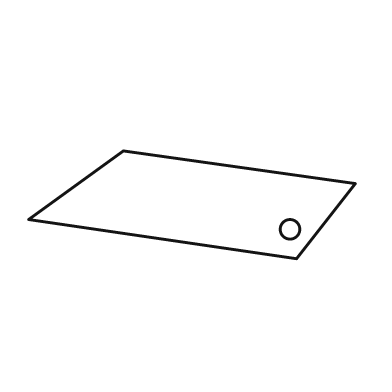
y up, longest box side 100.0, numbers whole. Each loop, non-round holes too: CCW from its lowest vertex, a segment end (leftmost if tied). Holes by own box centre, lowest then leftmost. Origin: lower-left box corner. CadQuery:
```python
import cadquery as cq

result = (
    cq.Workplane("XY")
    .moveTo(82.0, 0.0)
    .lineTo(100.0, 23.0)
    .lineTo(29.0, 33.0)
    .lineTo(0.0, 12.0)
    .close()
    .moveTo(80.0, 9.0)
    .circle(3.0)
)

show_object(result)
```